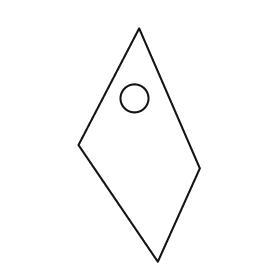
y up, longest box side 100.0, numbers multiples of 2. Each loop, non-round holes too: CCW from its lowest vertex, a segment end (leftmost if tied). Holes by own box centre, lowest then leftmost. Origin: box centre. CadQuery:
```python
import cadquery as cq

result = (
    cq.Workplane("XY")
    .moveTo(8.0, -50.0)
    .lineTo(26.0, -10.0)
    .lineTo(0.0, 50.0)
    .lineTo(-26.0, 0.0)
    .close()
    .moveTo(-2.0, 20.0)
    .circle(6.0)
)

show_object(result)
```